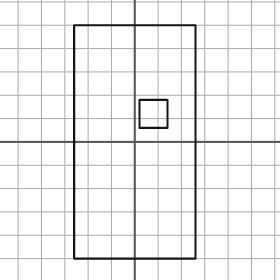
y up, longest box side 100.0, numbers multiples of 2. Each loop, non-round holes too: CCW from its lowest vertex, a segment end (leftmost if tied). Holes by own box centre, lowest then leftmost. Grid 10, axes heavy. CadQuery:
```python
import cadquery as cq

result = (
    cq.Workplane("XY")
    .moveTo(-26.0, -50.0)
    .lineTo(26.0, -50.0)
    .lineTo(26.0, 50.0)
    .lineTo(-26.0, 50.0)
    .close()
    .moveTo(2.0, 6.0)
    .lineTo(14.0, 6.0)
    .lineTo(14.0, 18.0)
    .lineTo(2.0, 18.0)
    .close()
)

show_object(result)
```